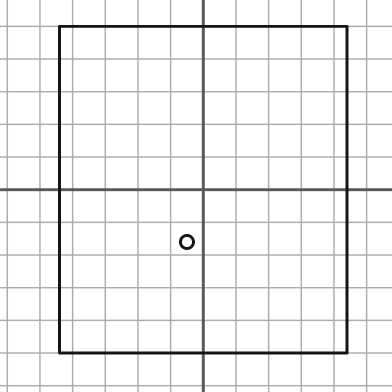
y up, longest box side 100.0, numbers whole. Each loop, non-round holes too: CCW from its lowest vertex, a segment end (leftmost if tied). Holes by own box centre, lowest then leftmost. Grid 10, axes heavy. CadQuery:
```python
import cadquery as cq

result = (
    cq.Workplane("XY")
    .moveTo(-44.0, -50.0)
    .lineTo(44.0, -50.0)
    .lineTo(44.0, 50.0)
    .lineTo(-44.0, 50.0)
    .close()
    .moveTo(-5.0, -16.0)
    .circle(2.0)
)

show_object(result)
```